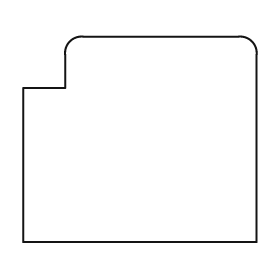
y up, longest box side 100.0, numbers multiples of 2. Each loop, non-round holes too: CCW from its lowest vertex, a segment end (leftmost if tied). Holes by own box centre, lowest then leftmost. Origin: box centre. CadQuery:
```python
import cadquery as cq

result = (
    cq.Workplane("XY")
    .moveTo(-50.0, -44.0)
    .lineTo(50.0, -44.0)
    .lineTo(50.0, 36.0)
    .threePointArc((48.0, 42.0), (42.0, 44.0))
    .lineTo(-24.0, 44.0)
    .threePointArc((-30.0, 42.0), (-32.0, 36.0))
    .lineTo(-32.0, 22.0)
    .lineTo(-50.0, 22.0)
    .close()
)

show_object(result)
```